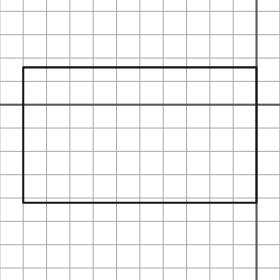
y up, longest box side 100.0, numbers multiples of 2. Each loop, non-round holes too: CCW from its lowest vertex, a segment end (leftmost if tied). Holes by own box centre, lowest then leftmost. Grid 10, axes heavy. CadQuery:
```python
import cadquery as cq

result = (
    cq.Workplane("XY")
    .moveTo(-100.0, -42.0)
    .lineTo(0.0, -42.0)
    .lineTo(0.0, 16.0)
    .lineTo(-100.0, 16.0)
    .close()
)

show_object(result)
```